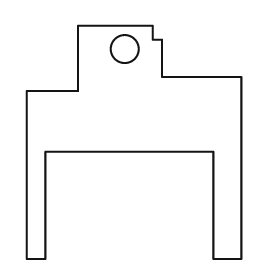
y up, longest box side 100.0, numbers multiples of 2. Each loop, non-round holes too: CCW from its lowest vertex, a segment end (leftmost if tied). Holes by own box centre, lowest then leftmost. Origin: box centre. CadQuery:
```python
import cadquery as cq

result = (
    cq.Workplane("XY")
    .moveTo(-46.0, -50.0)
    .lineTo(-38.0, -50.0)
    .lineTo(-38.0, -4.0)
    .lineTo(34.0, -4.0)
    .lineTo(34.0, -50.0)
    .lineTo(46.0, -50.0)
    .lineTo(46.0, 28.0)
    .lineTo(12.0, 28.0)
    .lineTo(12.0, 44.0)
    .lineTo(8.0, 44.0)
    .lineTo(8.0, 50.0)
    .lineTo(-24.0, 50.0)
    .lineTo(-24.0, 22.0)
    .lineTo(-46.0, 22.0)
    .close()
    .moveTo(-4.0, 40.0)
    .circle(6.0)
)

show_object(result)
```